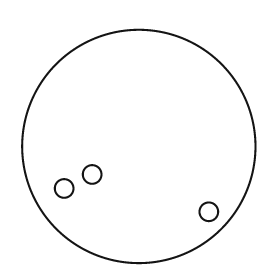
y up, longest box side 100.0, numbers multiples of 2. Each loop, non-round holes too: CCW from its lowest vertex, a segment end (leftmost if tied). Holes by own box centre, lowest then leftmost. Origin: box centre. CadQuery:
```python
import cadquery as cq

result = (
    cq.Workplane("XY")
    .moveTo(0.0, 0.0)
    .circle(50.0)
    .moveTo(30.0, -28.0)
    .circle(4.0)
    .moveTo(-32.0, -18.0)
    .circle(4.0)
    .moveTo(-20.0, -12.0)
    .circle(4.0)
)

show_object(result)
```